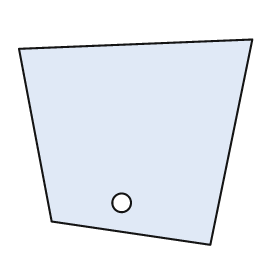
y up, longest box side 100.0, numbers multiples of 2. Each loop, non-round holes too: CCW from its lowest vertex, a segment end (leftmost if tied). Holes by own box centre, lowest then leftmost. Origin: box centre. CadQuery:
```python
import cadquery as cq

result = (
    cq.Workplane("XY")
    .moveTo(32.0, -44.0)
    .lineTo(50.0, 44.0)
    .lineTo(-50.0, 40.0)
    .lineTo(-36.0, -34.0)
    .close()
    .moveTo(-6.0, -26.0)
    .circle(4.0)
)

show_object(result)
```